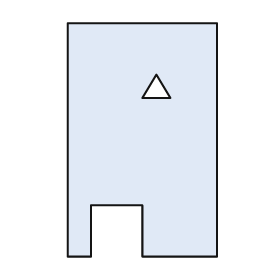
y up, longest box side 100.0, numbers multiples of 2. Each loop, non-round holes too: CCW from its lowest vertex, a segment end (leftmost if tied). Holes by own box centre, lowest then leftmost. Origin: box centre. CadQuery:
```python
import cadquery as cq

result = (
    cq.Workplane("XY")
    .moveTo(-32.0, -50.0)
    .lineTo(-22.0, -50.0)
    .lineTo(-22.0, -28.0)
    .lineTo(0.0, -28.0)
    .lineTo(0.0, -50.0)
    .lineTo(32.0, -50.0)
    .lineTo(32.0, 50.0)
    .lineTo(-32.0, 50.0)
    .close()
    .moveTo(0.0, 18.0)
    .lineTo(12.0, 18.0)
    .lineTo(6.0, 28.0)
    .close()
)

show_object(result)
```